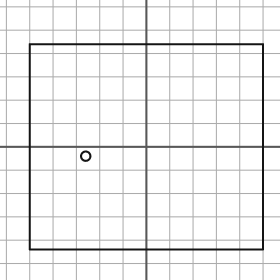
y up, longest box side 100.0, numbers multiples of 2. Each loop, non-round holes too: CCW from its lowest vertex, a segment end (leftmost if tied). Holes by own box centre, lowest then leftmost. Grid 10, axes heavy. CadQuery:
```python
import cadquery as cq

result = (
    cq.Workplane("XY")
    .moveTo(-50.0, -44.0)
    .lineTo(50.0, -44.0)
    .lineTo(50.0, 44.0)
    .lineTo(-50.0, 44.0)
    .close()
    .moveTo(-26.0, -4.0)
    .circle(2.0)
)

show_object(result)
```